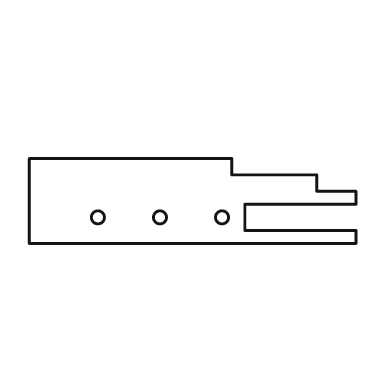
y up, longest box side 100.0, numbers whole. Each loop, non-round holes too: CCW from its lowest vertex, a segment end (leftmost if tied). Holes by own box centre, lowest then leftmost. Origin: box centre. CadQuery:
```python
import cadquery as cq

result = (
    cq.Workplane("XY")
    .moveTo(-50.0, -13.0)
    .lineTo(50.0, -13.0)
    .lineTo(50.0, -9.0)
    .lineTo(16.0, -9.0)
    .lineTo(16.0, -1.0)
    .lineTo(50.0, -1.0)
    .lineTo(50.0, 3.0)
    .lineTo(38.0, 3.0)
    .lineTo(38.0, 8.0)
    .lineTo(12.0, 8.0)
    .lineTo(12.0, 13.0)
    .lineTo(-50.0, 13.0)
    .close()
    .moveTo(-29.0, -5.0)
    .circle(2.0)
    .moveTo(-10.0, -5.0)
    .circle(2.0)
    .moveTo(9.0, -5.0)
    .circle(2.0)
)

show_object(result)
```